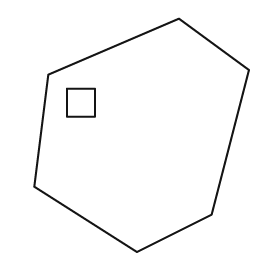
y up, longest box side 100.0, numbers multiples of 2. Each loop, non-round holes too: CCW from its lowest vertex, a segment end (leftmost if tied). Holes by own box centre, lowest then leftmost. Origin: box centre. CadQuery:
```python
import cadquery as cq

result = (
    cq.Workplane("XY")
    .moveTo(-2.0, -50.0)
    .lineTo(30.0, -34.0)
    .lineTo(46.0, 28.0)
    .lineTo(16.0, 50.0)
    .lineTo(-40.0, 26.0)
    .lineTo(-46.0, -22.0)
    .close()
    .moveTo(-32.0, 8.0)
    .lineTo(-20.0, 8.0)
    .lineTo(-20.0, 20.0)
    .lineTo(-32.0, 20.0)
    .close()
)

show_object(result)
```